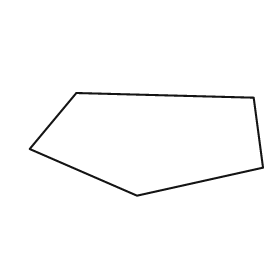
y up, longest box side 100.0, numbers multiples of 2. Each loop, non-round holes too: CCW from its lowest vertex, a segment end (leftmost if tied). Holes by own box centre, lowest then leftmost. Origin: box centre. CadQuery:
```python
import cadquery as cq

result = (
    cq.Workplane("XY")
    .moveTo(-4.0, -22.0)
    .lineTo(50.0, -10.0)
    .lineTo(46.0, 20.0)
    .lineTo(-30.0, 22.0)
    .lineTo(-50.0, -2.0)
    .close()
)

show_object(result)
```